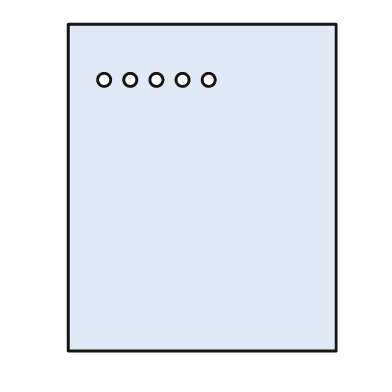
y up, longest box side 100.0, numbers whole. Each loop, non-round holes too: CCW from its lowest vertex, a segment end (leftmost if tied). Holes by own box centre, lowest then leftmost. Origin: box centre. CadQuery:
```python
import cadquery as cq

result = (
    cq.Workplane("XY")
    .moveTo(-41.0, -50.0)
    .lineTo(41.0, -50.0)
    .lineTo(41.0, 50.0)
    .lineTo(-41.0, 50.0)
    .close()
    .moveTo(-30.0, 33.0)
    .circle(2.0)
    .moveTo(-22.0, 33.0)
    .circle(2.0)
    .moveTo(-14.0, 33.0)
    .circle(2.0)
    .moveTo(-6.0, 33.0)
    .circle(2.0)
    .moveTo(2.0, 33.0)
    .circle(2.0)
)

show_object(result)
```